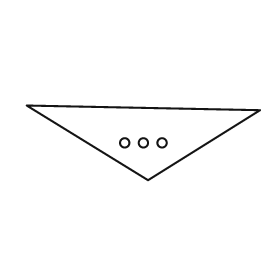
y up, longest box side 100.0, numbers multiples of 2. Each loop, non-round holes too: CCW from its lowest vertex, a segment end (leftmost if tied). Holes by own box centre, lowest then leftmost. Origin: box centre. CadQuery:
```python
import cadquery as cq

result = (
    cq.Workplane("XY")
    .moveTo(2.0, -16.0)
    .lineTo(50.0, 14.0)
    .lineTo(-50.0, 16.0)
    .close()
    .moveTo(-8.0, 0.0)
    .circle(2.0)
    .moveTo(0.0, 0.0)
    .circle(2.0)
    .moveTo(8.0, 0.0)
    .circle(2.0)
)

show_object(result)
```